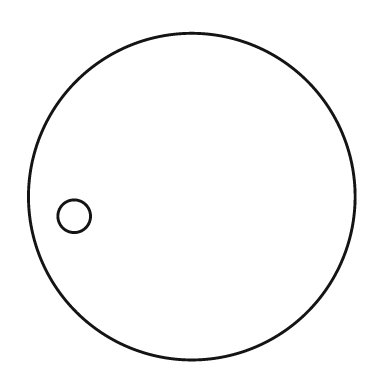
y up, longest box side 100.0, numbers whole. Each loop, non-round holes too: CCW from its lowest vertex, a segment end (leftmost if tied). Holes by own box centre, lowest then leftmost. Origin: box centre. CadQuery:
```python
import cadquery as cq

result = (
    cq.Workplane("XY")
    .moveTo(0.0, 0.0)
    .circle(50.0)
    .moveTo(-36.0, -6.0)
    .circle(5.0)
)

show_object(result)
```